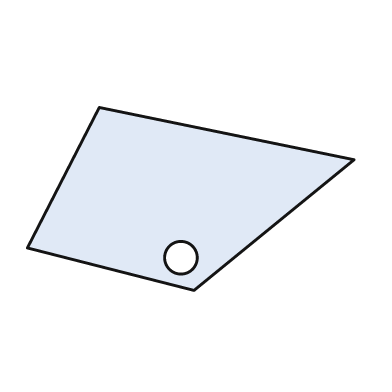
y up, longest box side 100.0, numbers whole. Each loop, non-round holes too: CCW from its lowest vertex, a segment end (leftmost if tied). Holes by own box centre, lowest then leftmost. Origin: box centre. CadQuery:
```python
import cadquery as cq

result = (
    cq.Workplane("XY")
    .moveTo(1.0, -28.0)
    .lineTo(50.0, 12.0)
    .lineTo(-28.0, 28.0)
    .lineTo(-50.0, -15.0)
    .close()
    .moveTo(-3.0, -18.0)
    .circle(5.0)
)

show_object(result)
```